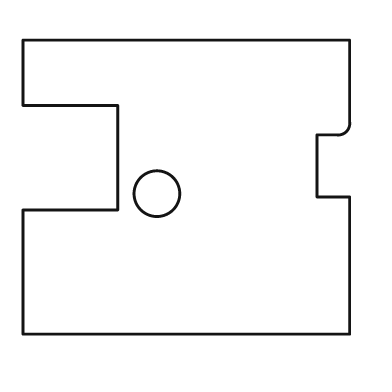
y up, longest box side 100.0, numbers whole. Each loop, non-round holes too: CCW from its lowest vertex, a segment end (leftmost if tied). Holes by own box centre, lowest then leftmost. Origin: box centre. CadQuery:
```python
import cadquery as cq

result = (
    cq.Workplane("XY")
    .moveTo(-50.0, -45.0)
    .lineTo(50.0, -45.0)
    .lineTo(50.0, -3.0)
    .lineTo(40.0, -3.0)
    .lineTo(40.0, 16.0)
    .lineTo(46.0, 16.0)
    .threePointArc((49.0, 17.0), (50.0, 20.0))
    .lineTo(50.0, 45.0)
    .lineTo(-50.0, 45.0)
    .lineTo(-50.0, 25.0)
    .lineTo(-21.0, 25.0)
    .lineTo(-21.0, -7.0)
    .lineTo(-50.0, -7.0)
    .close()
    .moveTo(-9.0, -2.0)
    .circle(7.0)
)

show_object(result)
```